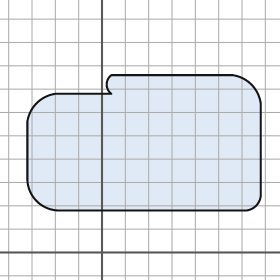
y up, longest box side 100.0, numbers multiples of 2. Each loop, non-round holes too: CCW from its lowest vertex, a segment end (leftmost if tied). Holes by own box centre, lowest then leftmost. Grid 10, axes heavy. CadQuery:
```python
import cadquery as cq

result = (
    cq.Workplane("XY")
    .moveTo(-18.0, 18.0)
    .lineTo(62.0, 18.0)
    .threePointArc((66.0, 20.0), (68.0, 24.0))
    .lineTo(68.0, 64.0)
    .threePointArc((64.0, 72.0), (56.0, 76.0))
    .lineTo(4.0, 76.0)
    .threePointArc((2.0, 72.0), (4.0, 68.0))
    .lineTo(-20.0, 68.0)
    .threePointArc((-28.0, 64.0), (-32.0, 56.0))
    .lineTo(-32.0, 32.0)
    .threePointArc((-28.0, 22.0), (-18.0, 18.0))
    .close()
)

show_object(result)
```